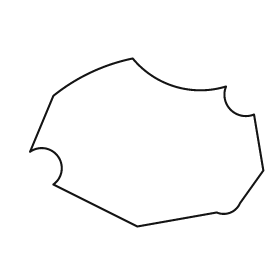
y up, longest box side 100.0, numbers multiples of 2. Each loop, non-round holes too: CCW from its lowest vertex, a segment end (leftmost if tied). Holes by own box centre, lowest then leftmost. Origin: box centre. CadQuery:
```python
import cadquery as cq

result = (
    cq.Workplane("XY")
    .moveTo(-4.0, -36.0)
    .lineTo(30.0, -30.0)
    .threePointArc((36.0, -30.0), (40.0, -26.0))
    .lineTo(50.0, -12.0)
    .lineTo(46.0, 12.0)
    .threePointArc((36.0, 14.0), (34.0, 24.0))
    .threePointArc((12.0, 24.0), (-6.0, 36.0))
    .threePointArc((-24.0, 30.0), (-40.0, 20.0))
    .lineTo(-50.0, -4.0)
    .threePointArc((-38.0, -6.0), (-40.0, -18.0))
    .close()
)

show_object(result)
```